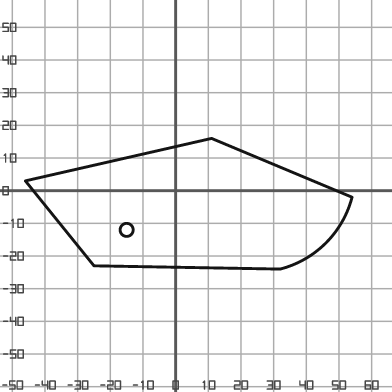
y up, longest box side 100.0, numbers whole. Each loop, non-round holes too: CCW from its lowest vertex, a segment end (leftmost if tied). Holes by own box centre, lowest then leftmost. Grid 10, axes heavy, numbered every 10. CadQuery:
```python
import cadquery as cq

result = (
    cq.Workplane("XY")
    .moveTo(32.0, -24.0)
    .threePointArc((46.0, -16.0), (54.0, -2.0))
    .lineTo(11.0, 16.0)
    .lineTo(-46.0, 3.0)
    .lineTo(-25.0, -23.0)
    .close()
    .moveTo(-15.0, -12.0)
    .circle(2.0)
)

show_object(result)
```